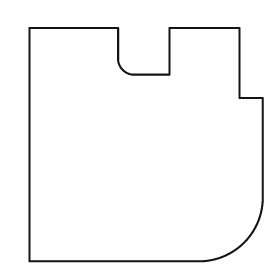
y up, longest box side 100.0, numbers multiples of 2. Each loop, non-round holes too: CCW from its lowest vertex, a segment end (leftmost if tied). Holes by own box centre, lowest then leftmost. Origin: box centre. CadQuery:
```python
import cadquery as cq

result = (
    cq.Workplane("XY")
    .moveTo(-50.0, -50.0)
    .lineTo(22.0, -50.0)
    .threePointArc((42.0, -42.0), (50.0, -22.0))
    .lineTo(50.0, 20.0)
    .lineTo(40.0, 20.0)
    .lineTo(40.0, 50.0)
    .lineTo(10.0, 50.0)
    .lineTo(10.0, 30.0)
    .lineTo(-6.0, 30.0)
    .threePointArc((-10.0, 32.0), (-12.0, 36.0))
    .lineTo(-12.0, 50.0)
    .lineTo(-50.0, 50.0)
    .close()
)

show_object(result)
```